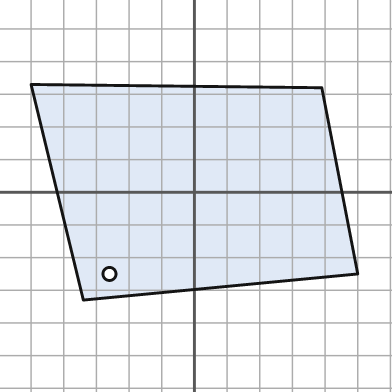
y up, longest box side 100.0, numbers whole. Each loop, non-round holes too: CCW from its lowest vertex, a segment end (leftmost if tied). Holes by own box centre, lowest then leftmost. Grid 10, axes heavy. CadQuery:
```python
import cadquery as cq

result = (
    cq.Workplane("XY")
    .moveTo(-34.0, -33.0)
    .lineTo(50.0, -25.0)
    .lineTo(39.0, 32.0)
    .lineTo(-50.0, 33.0)
    .close()
    .moveTo(-26.0, -25.0)
    .circle(2.0)
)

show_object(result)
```